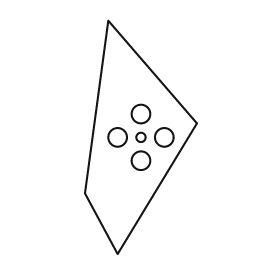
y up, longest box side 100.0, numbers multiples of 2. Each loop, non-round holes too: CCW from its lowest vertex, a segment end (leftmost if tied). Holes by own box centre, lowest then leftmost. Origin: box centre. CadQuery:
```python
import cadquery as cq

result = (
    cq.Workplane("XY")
    .moveTo(-10.0, -50.0)
    .lineTo(24.0, 6.0)
    .lineTo(-14.0, 50.0)
    .lineTo(-24.0, -24.0)
    .close()
    .moveTo(0.0, -10.0)
    .circle(4.0)
    .moveTo(-10.0, 0.0)
    .circle(4.0)
    .moveTo(0.0, 0.0)
    .circle(2.0)
    .moveTo(10.0, 0.0)
    .circle(4.0)
    .moveTo(0.0, 10.0)
    .circle(4.0)
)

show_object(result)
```